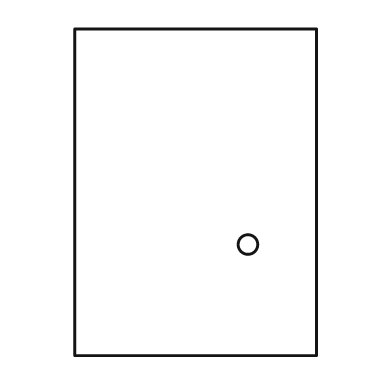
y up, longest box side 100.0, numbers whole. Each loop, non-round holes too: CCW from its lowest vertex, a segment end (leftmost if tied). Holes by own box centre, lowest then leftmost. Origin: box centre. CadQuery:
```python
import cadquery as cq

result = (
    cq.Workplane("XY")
    .moveTo(-37.0, -50.0)
    .lineTo(37.0, -50.0)
    .lineTo(37.0, 50.0)
    .lineTo(-37.0, 50.0)
    .close()
    .moveTo(16.0, -16.0)
    .circle(3.0)
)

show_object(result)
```